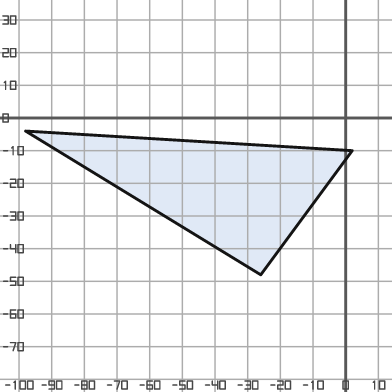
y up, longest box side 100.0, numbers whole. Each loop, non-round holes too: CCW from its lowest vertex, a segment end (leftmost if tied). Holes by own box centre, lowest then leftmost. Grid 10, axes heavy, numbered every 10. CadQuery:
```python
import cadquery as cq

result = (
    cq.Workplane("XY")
    .moveTo(-26.0, -48.0)
    .lineTo(2.0, -10.0)
    .lineTo(-98.0, -4.0)
    .close()
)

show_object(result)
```